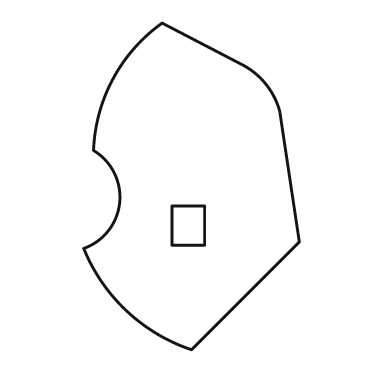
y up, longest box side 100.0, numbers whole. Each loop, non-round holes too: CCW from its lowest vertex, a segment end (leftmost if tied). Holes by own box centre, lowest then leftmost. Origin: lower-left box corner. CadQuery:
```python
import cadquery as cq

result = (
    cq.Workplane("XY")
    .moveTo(33.0, 0.0)
    .lineTo(66.0, 33.0)
    .lineTo(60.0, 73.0)
    .threePointArc((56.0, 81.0), (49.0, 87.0))
    .lineTo(24.0, 100.0)
    .threePointArc((9.0, 83.0), (3.0, 61.0))
    .threePointArc((11.0, 45.0), (0.0, 31.0))
    .threePointArc((13.0, 12.0), (33.0, 0.0))
    .close()
    .moveTo(27.0, 32.0)
    .lineTo(37.0, 32.0)
    .lineTo(37.0, 44.0)
    .lineTo(27.0, 44.0)
    .close()
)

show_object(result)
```